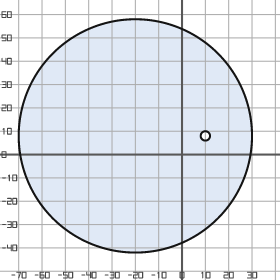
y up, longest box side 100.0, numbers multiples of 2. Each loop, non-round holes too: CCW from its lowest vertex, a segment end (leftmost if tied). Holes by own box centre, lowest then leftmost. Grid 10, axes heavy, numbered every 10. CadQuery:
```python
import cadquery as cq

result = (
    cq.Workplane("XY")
    .moveTo(-20.0, 8.0)
    .circle(50.0)
    .moveTo(10.0, 8.0)
    .circle(2.0)
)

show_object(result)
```